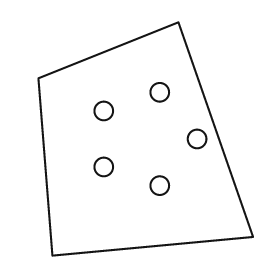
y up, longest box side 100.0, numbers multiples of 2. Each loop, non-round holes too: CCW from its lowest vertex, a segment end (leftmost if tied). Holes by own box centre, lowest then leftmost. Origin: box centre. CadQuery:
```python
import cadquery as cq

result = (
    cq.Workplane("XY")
    .moveTo(-40.0, -50.0)
    .lineTo(46.0, -42.0)
    .lineTo(14.0, 50.0)
    .lineTo(-46.0, 26.0)
    .close()
    .moveTo(6.0, -20.0)
    .circle(4.0)
    .moveTo(-18.0, -12.0)
    .circle(4.0)
    .moveTo(22.0, 0.0)
    .circle(4.0)
    .moveTo(-18.0, 12.0)
    .circle(4.0)
    .moveTo(6.0, 20.0)
    .circle(4.0)
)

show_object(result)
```